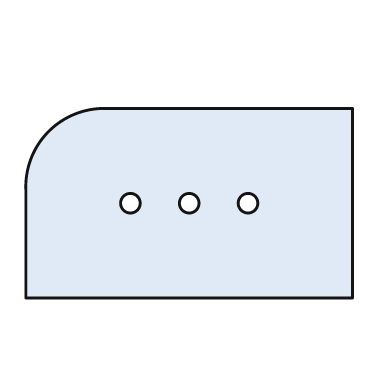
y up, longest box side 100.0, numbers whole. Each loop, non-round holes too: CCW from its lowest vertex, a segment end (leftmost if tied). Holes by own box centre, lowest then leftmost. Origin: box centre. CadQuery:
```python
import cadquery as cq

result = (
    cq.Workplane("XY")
    .moveTo(-50.0, -29.0)
    .lineTo(50.0, -29.0)
    .lineTo(50.0, 29.0)
    .lineTo(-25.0, 29.0)
    .threePointArc((-43.0, 22.0), (-50.0, 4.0))
    .close()
    .moveTo(-18.0, 0.0)
    .circle(3.0)
    .moveTo(0.0, 0.0)
    .circle(3.0)
    .moveTo(18.0, 0.0)
    .circle(3.0)
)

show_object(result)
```